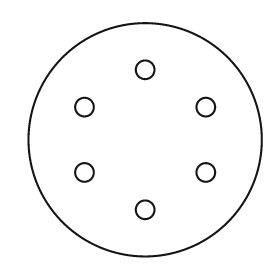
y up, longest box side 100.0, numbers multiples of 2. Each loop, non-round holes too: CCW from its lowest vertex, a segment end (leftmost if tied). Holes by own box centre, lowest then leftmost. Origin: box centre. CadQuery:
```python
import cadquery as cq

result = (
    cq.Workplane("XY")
    .moveTo(0.0, 0.0)
    .circle(50.0)
    .moveTo(0.0, -30.0)
    .circle(4.0)
    .moveTo(-26.0, -14.0)
    .circle(4.0)
    .moveTo(26.0, -14.0)
    .circle(4.0)
    .moveTo(-26.0, 14.0)
    .circle(4.0)
    .moveTo(26.0, 14.0)
    .circle(4.0)
    .moveTo(0.0, 30.0)
    .circle(4.0)
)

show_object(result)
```